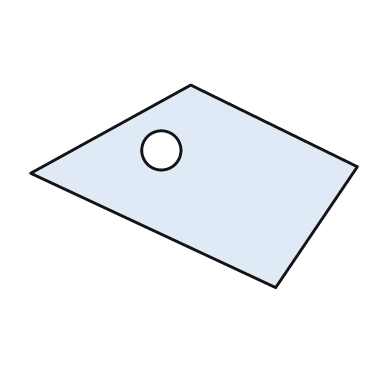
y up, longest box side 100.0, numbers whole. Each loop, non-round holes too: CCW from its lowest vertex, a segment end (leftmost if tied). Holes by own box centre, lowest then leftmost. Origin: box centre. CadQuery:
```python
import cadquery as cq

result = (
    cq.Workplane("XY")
    .moveTo(25.0, -31.0)
    .lineTo(50.0, 6.0)
    .lineTo(-1.0, 31.0)
    .lineTo(-50.0, 4.0)
    .close()
    .moveTo(-10.0, 11.0)
    .circle(6.0)
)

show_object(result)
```